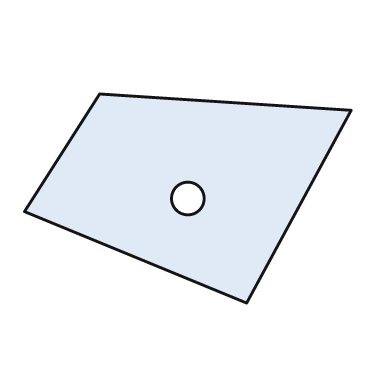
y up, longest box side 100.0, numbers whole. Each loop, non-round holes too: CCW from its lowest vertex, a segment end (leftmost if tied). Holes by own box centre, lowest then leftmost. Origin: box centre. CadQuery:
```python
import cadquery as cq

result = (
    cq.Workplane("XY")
    .moveTo(18.0, -32.0)
    .lineTo(50.0, 27.0)
    .lineTo(-27.0, 32.0)
    .lineTo(-50.0, -4.0)
    .close()
    .moveTo(0.0, 0.0)
    .circle(5.0)
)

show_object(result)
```